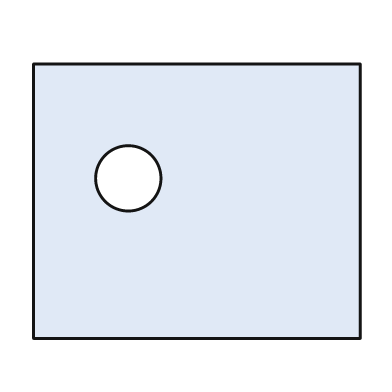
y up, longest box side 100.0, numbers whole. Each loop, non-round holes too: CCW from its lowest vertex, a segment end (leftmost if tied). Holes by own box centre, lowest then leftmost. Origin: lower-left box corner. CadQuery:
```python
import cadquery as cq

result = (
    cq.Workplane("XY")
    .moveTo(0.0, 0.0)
    .lineTo(100.0, 0.0)
    .lineTo(100.0, 84.0)
    .lineTo(0.0, 84.0)
    .close()
    .moveTo(29.0, 49.0)
    .circle(10.0)
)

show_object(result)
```